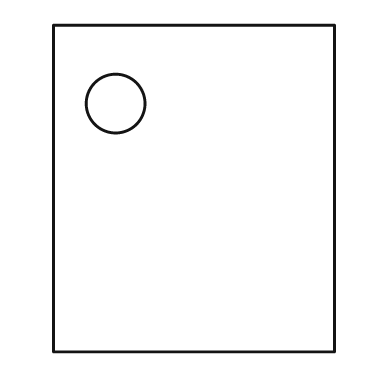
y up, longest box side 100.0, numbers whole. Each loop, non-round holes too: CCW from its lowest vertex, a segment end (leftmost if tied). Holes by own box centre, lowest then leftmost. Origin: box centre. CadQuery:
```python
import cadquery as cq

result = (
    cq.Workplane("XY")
    .moveTo(-43.0, -50.0)
    .lineTo(43.0, -50.0)
    .lineTo(43.0, 50.0)
    .lineTo(-43.0, 50.0)
    .close()
    .moveTo(-24.0, 26.0)
    .circle(9.0)
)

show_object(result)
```